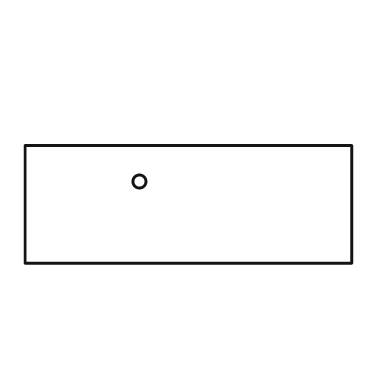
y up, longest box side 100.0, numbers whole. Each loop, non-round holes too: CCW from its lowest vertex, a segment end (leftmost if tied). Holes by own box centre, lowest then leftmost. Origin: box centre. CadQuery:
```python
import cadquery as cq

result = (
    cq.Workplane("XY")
    .moveTo(-50.0, -18.0)
    .lineTo(50.0, -18.0)
    .lineTo(50.0, 18.0)
    .lineTo(-50.0, 18.0)
    .close()
    .moveTo(-15.0, 7.0)
    .circle(2.0)
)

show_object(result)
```